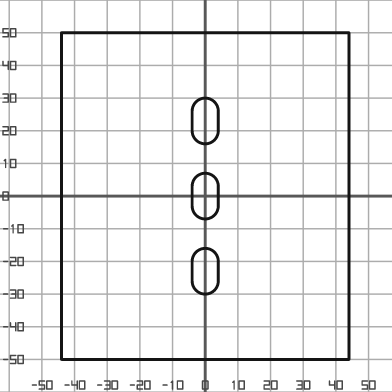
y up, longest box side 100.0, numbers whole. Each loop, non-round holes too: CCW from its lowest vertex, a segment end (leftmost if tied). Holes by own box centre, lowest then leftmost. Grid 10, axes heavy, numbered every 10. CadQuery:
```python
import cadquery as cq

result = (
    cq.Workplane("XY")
    .moveTo(-44.0, -50.0)
    .lineTo(44.0, -50.0)
    .lineTo(44.0, 50.0)
    .lineTo(-44.0, 50.0)
    .close()
    .moveTo(-4.0, -26.0)
    .threePointArc((0.0, -30.0), (4.0, -26.0))
    .lineTo(4.0, -20.0)
    .threePointArc((0.0, -16.0), (-4.0, -20.0))
    .close()
    .moveTo(-4.0, -3.0)
    .threePointArc((0.0, -7.0), (4.0, -3.0))
    .lineTo(4.0, 3.0)
    .threePointArc((0.0, 7.0), (-4.0, 3.0))
    .close()
    .moveTo(-4.0, 20.0)
    .threePointArc((0.0, 16.0), (4.0, 20.0))
    .lineTo(4.0, 26.0)
    .threePointArc((0.0, 30.0), (-4.0, 26.0))
    .close()
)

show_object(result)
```